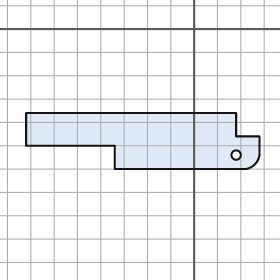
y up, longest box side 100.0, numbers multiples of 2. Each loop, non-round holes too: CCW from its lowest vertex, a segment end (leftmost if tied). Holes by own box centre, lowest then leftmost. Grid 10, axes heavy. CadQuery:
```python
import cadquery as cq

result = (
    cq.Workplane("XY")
    .moveTo(-34.0, -60.0)
    .lineTo(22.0, -60.0)
    .threePointArc((26.0, -58.0), (28.0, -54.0))
    .lineTo(28.0, -46.0)
    .lineTo(18.0, -46.0)
    .lineTo(18.0, -36.0)
    .lineTo(-72.0, -36.0)
    .lineTo(-72.0, -50.0)
    .lineTo(-34.0, -50.0)
    .close()
    .moveTo(18.0, -54.0)
    .circle(2.0)
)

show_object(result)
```